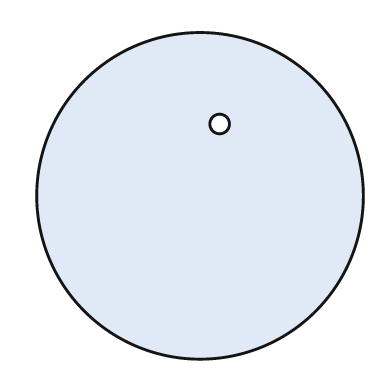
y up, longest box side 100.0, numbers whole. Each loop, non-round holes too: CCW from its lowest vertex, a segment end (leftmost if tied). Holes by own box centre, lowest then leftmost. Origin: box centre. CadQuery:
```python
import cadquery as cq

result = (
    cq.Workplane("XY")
    .moveTo(0.0, 0.0)
    .circle(50.0)
    .moveTo(6.0, 22.0)
    .circle(3.0)
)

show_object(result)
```